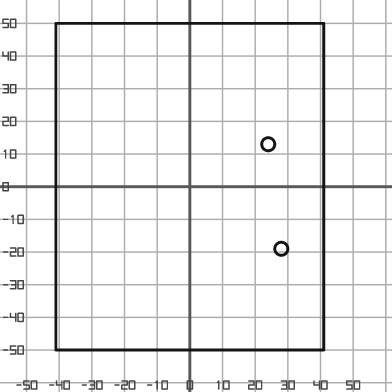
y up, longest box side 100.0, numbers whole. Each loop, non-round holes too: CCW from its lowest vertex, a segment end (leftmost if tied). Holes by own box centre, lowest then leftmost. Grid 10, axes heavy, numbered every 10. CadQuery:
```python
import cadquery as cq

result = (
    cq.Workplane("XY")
    .moveTo(-41.0, -50.0)
    .lineTo(41.0, -50.0)
    .lineTo(41.0, 50.0)
    .lineTo(-41.0, 50.0)
    .close()
    .moveTo(28.0, -19.0)
    .circle(2.0)
    .moveTo(24.0, 13.0)
    .circle(2.0)
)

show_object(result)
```